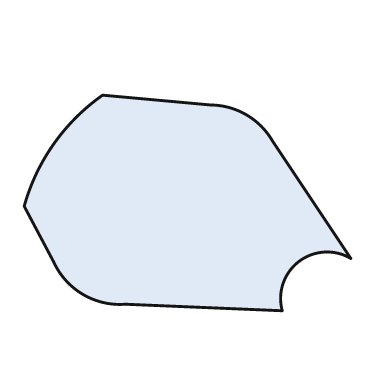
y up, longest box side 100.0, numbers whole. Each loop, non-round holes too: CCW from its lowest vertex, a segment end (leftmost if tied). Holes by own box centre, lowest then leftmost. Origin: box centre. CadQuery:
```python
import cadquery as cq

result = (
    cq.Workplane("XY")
    .moveTo(29.0, -33.0)
    .threePointArc((34.0, -18.0), (50.0, -17.0))
    .lineTo(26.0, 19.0)
    .threePointArc((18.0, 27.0), (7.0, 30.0))
    .lineTo(-26.0, 33.0)
    .threePointArc((-41.0, 18.0), (-50.0, -1.0))
    .lineTo(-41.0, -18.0)
    .threePointArc((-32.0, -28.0), (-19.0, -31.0))
    .close()
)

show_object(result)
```